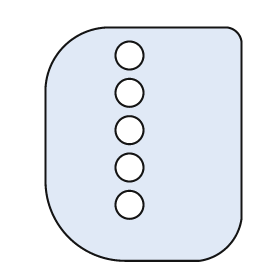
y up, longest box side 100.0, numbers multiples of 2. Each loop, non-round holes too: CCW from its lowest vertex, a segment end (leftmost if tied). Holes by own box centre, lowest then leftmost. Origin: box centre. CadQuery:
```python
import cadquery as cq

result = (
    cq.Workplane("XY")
    .moveTo(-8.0, -50.0)
    .lineTo(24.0, -50.0)
    .threePointArc((36.0, -44.0), (42.0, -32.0))
    .lineTo(42.0, 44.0)
    .threePointArc((40.0, 48.0), (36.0, 50.0))
    .lineTo(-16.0, 50.0)
    .threePointArc((-34.0, 42.0), (-42.0, 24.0))
    .lineTo(-42.0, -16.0)
    .threePointArc((-32.0, -40.0), (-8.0, -50.0))
    .close()
    .moveTo(-6.0, -26.0)
    .circle(6.0)
    .moveTo(-6.0, -10.0)
    .circle(6.0)
    .moveTo(-6.0, 6.0)
    .circle(6.0)
    .moveTo(-6.0, 22.0)
    .circle(6.0)
    .moveTo(-6.0, 38.0)
    .circle(6.0)
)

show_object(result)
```